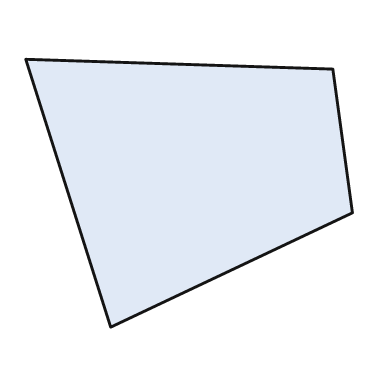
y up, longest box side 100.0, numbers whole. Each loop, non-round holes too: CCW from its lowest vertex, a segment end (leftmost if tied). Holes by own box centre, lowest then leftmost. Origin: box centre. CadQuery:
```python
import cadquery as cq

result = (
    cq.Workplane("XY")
    .moveTo(-24.0, -41.0)
    .lineTo(50.0, -6.0)
    .lineTo(44.0, 38.0)
    .lineTo(-50.0, 41.0)
    .close()
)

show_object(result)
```